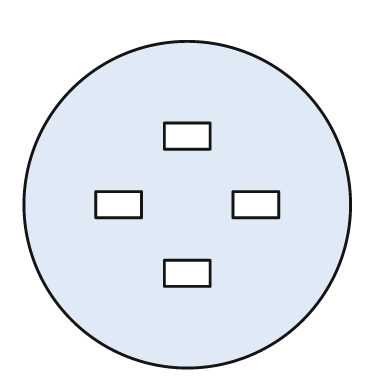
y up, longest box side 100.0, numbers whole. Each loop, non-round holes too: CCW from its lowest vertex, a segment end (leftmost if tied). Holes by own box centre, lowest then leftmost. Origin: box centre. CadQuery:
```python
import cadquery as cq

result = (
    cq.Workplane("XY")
    .moveTo(0.0, 0.0)
    .circle(50.0)
    .moveTo(-7.0, -25.0)
    .lineTo(7.0, -25.0)
    .lineTo(7.0, -17.0)
    .lineTo(-7.0, -17.0)
    .close()
    .moveTo(-28.0, -4.0)
    .lineTo(-14.0, -4.0)
    .lineTo(-14.0, 4.0)
    .lineTo(-28.0, 4.0)
    .close()
    .moveTo(14.0, -4.0)
    .lineTo(28.0, -4.0)
    .lineTo(28.0, 4.0)
    .lineTo(14.0, 4.0)
    .close()
    .moveTo(-7.0, 17.0)
    .lineTo(7.0, 17.0)
    .lineTo(7.0, 25.0)
    .lineTo(-7.0, 25.0)
    .close()
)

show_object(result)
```